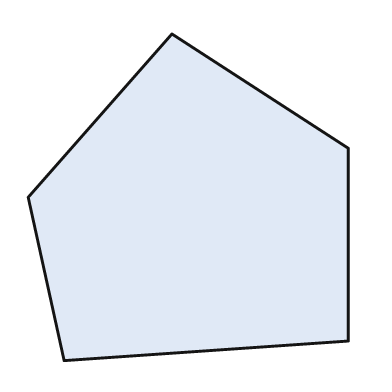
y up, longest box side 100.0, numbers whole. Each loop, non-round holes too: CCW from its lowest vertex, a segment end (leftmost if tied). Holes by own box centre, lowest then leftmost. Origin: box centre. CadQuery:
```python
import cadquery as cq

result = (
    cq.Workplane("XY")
    .moveTo(-38.0, -50.0)
    .lineTo(49.0, -44.0)
    .lineTo(49.0, 15.0)
    .lineTo(-5.0, 50.0)
    .lineTo(-49.0, 0.0)
    .close()
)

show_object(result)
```